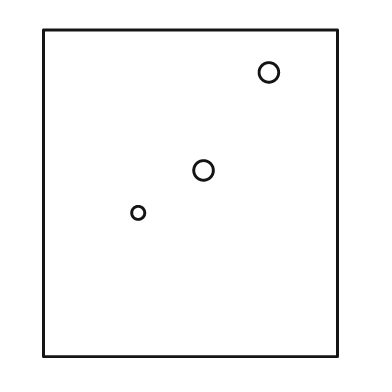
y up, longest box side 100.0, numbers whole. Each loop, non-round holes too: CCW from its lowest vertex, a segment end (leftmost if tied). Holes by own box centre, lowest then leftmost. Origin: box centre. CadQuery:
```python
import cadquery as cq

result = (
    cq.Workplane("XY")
    .moveTo(-45.0, -50.0)
    .lineTo(45.0, -50.0)
    .lineTo(45.0, 50.0)
    .lineTo(-45.0, 50.0)
    .close()
    .moveTo(-16.0, -6.0)
    .circle(2.0)
    .moveTo(4.0, 7.0)
    .circle(3.0)
    .moveTo(24.0, 37.0)
    .circle(3.0)
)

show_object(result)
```